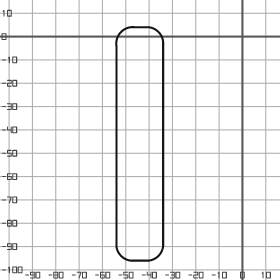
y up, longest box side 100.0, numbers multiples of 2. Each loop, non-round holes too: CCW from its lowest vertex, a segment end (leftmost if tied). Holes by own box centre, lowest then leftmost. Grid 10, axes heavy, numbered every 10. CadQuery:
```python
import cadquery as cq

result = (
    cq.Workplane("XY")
    .moveTo(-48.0, -96.0)
    .lineTo(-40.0, -96.0)
    .threePointArc((-36.0, -94.0), (-34.0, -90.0))
    .lineTo(-34.0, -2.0)
    .threePointArc((-36.0, 2.0), (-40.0, 4.0))
    .lineTo(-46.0, 4.0)
    .threePointArc((-52.0, 2.0), (-54.0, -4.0))
    .lineTo(-54.0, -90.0)
    .threePointArc((-52.0, -94.0), (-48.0, -96.0))
    .close()
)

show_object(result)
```